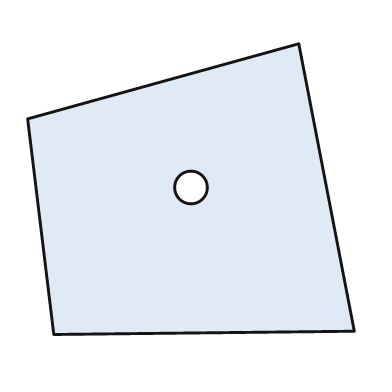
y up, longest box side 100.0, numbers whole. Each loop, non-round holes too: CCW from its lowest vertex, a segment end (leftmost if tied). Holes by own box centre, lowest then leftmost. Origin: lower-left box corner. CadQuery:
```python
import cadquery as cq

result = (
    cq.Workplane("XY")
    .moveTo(8.0, 0.0)
    .lineTo(100.0, 1.0)
    .lineTo(83.0, 89.0)
    .lineTo(0.0, 66.0)
    .close()
    .moveTo(50.0, 45.0)
    .circle(5.0)
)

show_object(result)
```